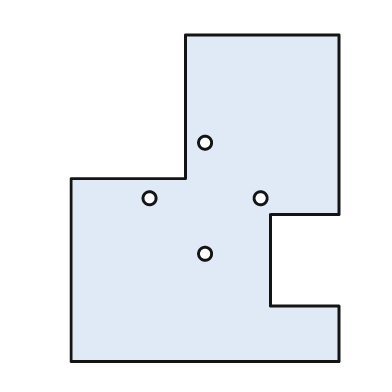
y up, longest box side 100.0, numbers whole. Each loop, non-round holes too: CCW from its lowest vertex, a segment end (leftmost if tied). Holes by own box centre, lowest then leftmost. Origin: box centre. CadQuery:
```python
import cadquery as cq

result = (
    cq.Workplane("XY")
    .moveTo(-41.0, -50.0)
    .lineTo(41.0, -50.0)
    .lineTo(41.0, -33.0)
    .lineTo(20.0, -33.0)
    .lineTo(20.0, -5.0)
    .lineTo(41.0, -5.0)
    .lineTo(41.0, 50.0)
    .lineTo(-6.0, 50.0)
    .lineTo(-6.0, 6.0)
    .lineTo(-41.0, 6.0)
    .close()
    .moveTo(0.0, -17.0)
    .circle(2.0)
    .moveTo(-17.0, 0.0)
    .circle(2.0)
    .moveTo(17.0, 0.0)
    .circle(2.0)
    .moveTo(0.0, 17.0)
    .circle(2.0)
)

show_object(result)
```